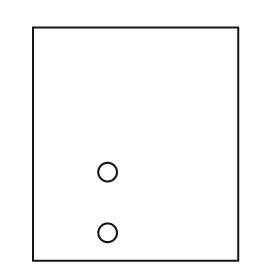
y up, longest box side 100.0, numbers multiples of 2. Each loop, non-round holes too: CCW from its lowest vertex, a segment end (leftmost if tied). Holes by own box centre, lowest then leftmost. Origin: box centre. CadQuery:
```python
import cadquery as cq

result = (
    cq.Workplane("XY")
    .moveTo(-44.0, -50.0)
    .lineTo(44.0, -50.0)
    .lineTo(44.0, 50.0)
    .lineTo(-44.0, 50.0)
    .close()
    .moveTo(-12.0, -38.0)
    .circle(4.0)
    .moveTo(-12.0, -12.0)
    .circle(4.0)
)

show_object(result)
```